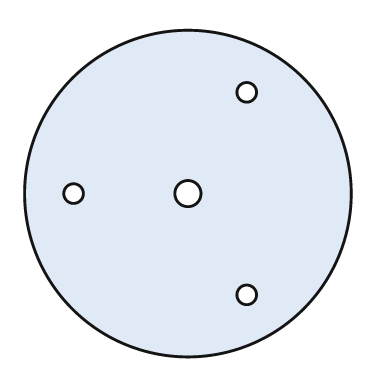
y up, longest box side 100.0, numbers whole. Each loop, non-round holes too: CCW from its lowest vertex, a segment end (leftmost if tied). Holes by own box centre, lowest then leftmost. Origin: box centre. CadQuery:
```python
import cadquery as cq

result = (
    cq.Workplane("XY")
    .moveTo(0.0, 0.0)
    .circle(50.0)
    .moveTo(18.0, -31.0)
    .circle(3.0)
    .moveTo(-35.0, 0.0)
    .circle(3.0)
    .moveTo(0.0, 0.0)
    .circle(4.0)
    .moveTo(18.0, 31.0)
    .circle(3.0)
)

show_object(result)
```